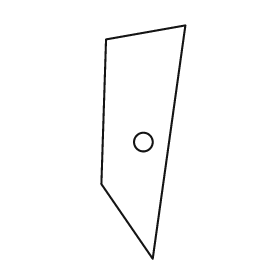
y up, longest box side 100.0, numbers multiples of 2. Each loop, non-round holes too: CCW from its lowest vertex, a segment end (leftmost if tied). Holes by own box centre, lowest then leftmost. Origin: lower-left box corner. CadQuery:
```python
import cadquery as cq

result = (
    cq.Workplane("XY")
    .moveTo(22.0, 0.0)
    .lineTo(36.0, 100.0)
    .lineTo(2.0, 94.0)
    .lineTo(0.0, 32.0)
    .close()
    .moveTo(18.0, 50.0)
    .circle(4.0)
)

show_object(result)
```